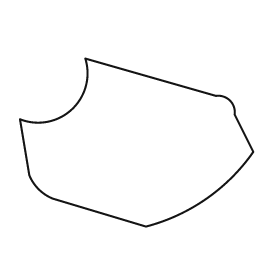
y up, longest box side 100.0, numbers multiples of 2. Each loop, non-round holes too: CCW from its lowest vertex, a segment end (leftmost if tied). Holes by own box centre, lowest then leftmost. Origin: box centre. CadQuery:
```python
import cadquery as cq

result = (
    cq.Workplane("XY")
    .moveTo(4.0, -36.0)
    .threePointArc((30.0, -24.0), (50.0, -4.0))
    .lineTo(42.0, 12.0)
    .threePointArc((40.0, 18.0), (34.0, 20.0))
    .lineTo(-22.0, 36.0)
    .threePointArc((-28.0, 14.0), (-50.0, 10.0))
    .lineTo(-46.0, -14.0)
    .threePointArc((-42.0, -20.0), (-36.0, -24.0))
    .close()
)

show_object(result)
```